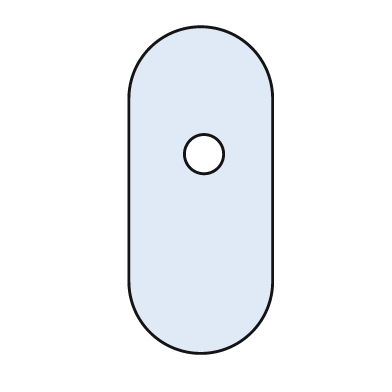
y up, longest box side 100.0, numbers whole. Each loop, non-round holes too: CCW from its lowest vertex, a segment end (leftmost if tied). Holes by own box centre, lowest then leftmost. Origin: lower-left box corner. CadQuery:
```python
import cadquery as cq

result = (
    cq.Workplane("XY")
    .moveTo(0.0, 22.0)
    .threePointArc((22.0, 0.0), (44.0, 22.0))
    .lineTo(44.0, 78.0)
    .threePointArc((22.0, 100.0), (0.0, 78.0))
    .close()
    .moveTo(23.0, 61.0)
    .circle(6.0)
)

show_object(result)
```